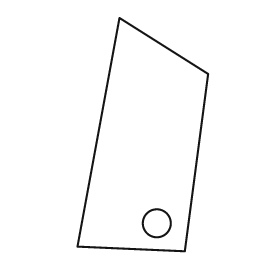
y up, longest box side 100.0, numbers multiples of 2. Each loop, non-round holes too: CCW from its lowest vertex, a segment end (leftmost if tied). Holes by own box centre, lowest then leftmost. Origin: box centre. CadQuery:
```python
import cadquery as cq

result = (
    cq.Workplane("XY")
    .moveTo(18.0, -50.0)
    .lineTo(28.0, 26.0)
    .lineTo(-10.0, 50.0)
    .lineTo(-28.0, -48.0)
    .close()
    .moveTo(6.0, -38.0)
    .circle(6.0)
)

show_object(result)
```